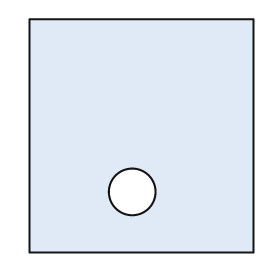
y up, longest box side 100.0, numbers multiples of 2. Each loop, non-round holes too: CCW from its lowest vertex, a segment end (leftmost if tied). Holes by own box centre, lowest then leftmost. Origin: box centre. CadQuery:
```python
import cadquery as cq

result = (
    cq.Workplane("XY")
    .moveTo(-48.0, -50.0)
    .lineTo(48.0, -50.0)
    .lineTo(48.0, 50.0)
    .lineTo(-48.0, 50.0)
    .close()
    .moveTo(-4.0, -24.0)
    .circle(10.0)
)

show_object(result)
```